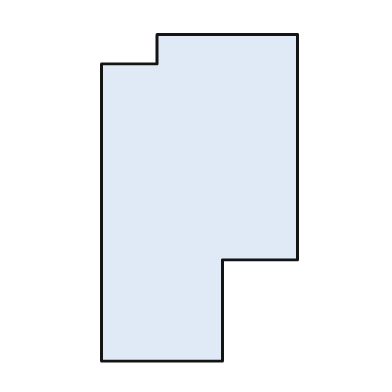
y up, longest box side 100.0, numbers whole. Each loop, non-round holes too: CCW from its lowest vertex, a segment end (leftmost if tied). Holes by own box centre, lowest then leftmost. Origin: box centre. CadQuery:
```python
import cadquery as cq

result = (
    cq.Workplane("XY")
    .moveTo(-30.0, -50.0)
    .lineTo(7.0, -50.0)
    .lineTo(7.0, -19.0)
    .lineTo(30.0, -19.0)
    .lineTo(30.0, 50.0)
    .lineTo(-13.0, 50.0)
    .lineTo(-13.0, 41.0)
    .lineTo(-30.0, 41.0)
    .close()
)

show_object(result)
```